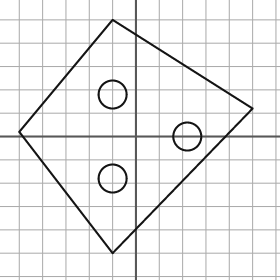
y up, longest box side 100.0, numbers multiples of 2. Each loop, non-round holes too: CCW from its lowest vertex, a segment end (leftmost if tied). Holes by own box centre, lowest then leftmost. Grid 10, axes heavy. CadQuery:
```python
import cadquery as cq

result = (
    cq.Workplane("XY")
    .moveTo(-10.0, -50.0)
    .lineTo(50.0, 12.0)
    .lineTo(-10.0, 50.0)
    .lineTo(-50.0, 2.0)
    .close()
    .moveTo(-10.0, -18.0)
    .circle(6.0)
    .moveTo(22.0, 0.0)
    .circle(6.0)
    .moveTo(-10.0, 18.0)
    .circle(6.0)
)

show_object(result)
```